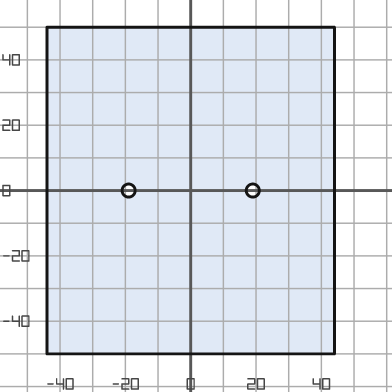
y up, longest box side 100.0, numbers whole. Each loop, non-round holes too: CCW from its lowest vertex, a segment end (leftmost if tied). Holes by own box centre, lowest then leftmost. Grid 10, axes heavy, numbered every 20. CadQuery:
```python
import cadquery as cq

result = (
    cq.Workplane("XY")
    .moveTo(-44.0, -50.0)
    .lineTo(44.0, -50.0)
    .lineTo(44.0, 50.0)
    .lineTo(-44.0, 50.0)
    .close()
    .moveTo(-19.0, 0.0)
    .circle(2.0)
    .moveTo(19.0, 0.0)
    .circle(2.0)
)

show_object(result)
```